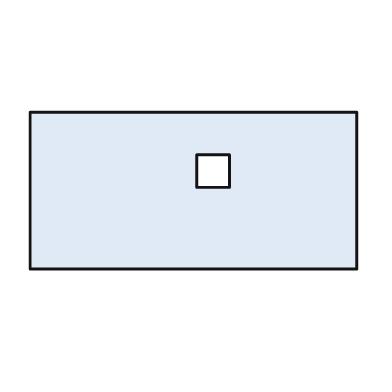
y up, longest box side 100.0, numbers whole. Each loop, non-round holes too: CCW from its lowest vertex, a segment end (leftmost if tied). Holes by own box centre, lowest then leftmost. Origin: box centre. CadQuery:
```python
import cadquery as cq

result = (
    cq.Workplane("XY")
    .moveTo(-50.0, -24.0)
    .lineTo(50.0, -24.0)
    .lineTo(50.0, 24.0)
    .lineTo(-50.0, 24.0)
    .close()
    .moveTo(1.0, 1.0)
    .lineTo(11.0, 1.0)
    .lineTo(11.0, 11.0)
    .lineTo(1.0, 11.0)
    .close()
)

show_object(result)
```